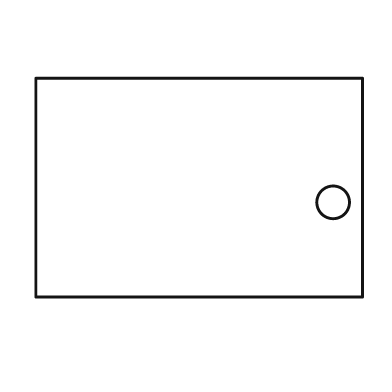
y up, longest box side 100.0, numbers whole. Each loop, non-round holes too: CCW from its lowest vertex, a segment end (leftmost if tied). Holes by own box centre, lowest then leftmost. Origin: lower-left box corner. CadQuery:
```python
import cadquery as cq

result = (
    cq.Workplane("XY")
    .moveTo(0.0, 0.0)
    .lineTo(100.0, 0.0)
    .lineTo(100.0, 67.0)
    .lineTo(0.0, 67.0)
    .close()
    .moveTo(91.0, 29.0)
    .circle(5.0)
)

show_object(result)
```